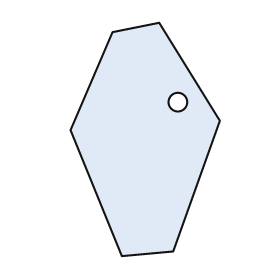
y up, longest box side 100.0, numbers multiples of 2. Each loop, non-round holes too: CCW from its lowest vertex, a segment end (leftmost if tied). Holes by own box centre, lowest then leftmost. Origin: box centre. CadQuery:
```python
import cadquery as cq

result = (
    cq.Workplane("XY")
    .moveTo(-10.0, -50.0)
    .lineTo(12.0, -48.0)
    .lineTo(32.0, 8.0)
    .lineTo(6.0, 50.0)
    .lineTo(-14.0, 46.0)
    .lineTo(-32.0, 4.0)
    .close()
    .moveTo(14.0, 16.0)
    .circle(4.0)
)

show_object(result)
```